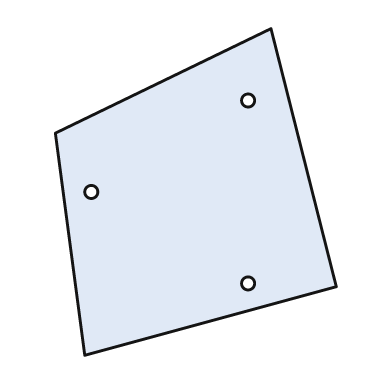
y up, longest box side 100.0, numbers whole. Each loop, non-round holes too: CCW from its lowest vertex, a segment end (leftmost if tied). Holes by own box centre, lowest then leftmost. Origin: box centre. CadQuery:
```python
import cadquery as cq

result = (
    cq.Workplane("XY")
    .moveTo(-34.0, -50.0)
    .lineTo(43.0, -29.0)
    .lineTo(23.0, 50.0)
    .lineTo(-43.0, 18.0)
    .close()
    .moveTo(16.0, -28.0)
    .circle(2.0)
    .moveTo(-32.0, 0.0)
    .circle(2.0)
    .moveTo(16.0, 28.0)
    .circle(2.0)
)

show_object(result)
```